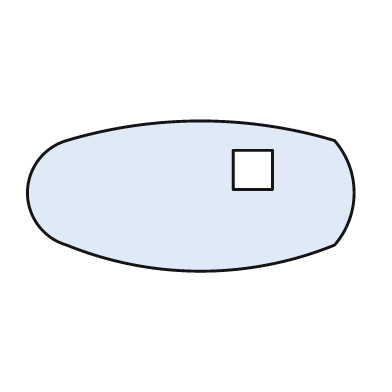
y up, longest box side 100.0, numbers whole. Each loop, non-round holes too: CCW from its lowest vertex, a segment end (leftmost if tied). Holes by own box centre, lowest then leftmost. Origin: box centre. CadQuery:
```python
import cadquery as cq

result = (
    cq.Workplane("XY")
    .moveTo(-38.0, -15.0)
    .threePointArc((3.0, -23.0), (44.0, -15.0))
    .threePointArc((50.0, 1.0), (44.0, 17.0))
    .threePointArc((3.0, 23.0), (-38.0, 17.0))
    .threePointArc((-50.0, 1.0), (-38.0, -15.0))
    .close()
    .moveTo(13.0, 2.0)
    .lineTo(25.0, 2.0)
    .lineTo(25.0, 14.0)
    .lineTo(13.0, 14.0)
    .close()
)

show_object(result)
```